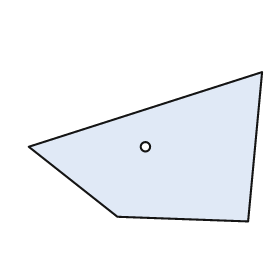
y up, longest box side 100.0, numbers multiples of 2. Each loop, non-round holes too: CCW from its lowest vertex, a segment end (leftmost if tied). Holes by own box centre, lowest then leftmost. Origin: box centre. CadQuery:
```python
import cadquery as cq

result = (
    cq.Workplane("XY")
    .moveTo(44.0, -32.0)
    .lineTo(50.0, 32.0)
    .lineTo(-50.0, 0.0)
    .lineTo(-12.0, -30.0)
    .close()
    .moveTo(0.0, 0.0)
    .circle(2.0)
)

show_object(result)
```